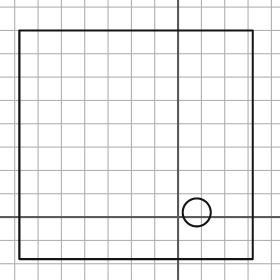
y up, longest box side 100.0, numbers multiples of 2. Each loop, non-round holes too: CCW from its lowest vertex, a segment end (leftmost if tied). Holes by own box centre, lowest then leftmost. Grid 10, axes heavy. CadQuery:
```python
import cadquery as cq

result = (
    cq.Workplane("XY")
    .moveTo(-68.0, -18.0)
    .lineTo(32.0, -18.0)
    .lineTo(32.0, 80.0)
    .lineTo(-68.0, 80.0)
    .close()
    .moveTo(8.0, 2.0)
    .circle(6.0)
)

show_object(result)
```